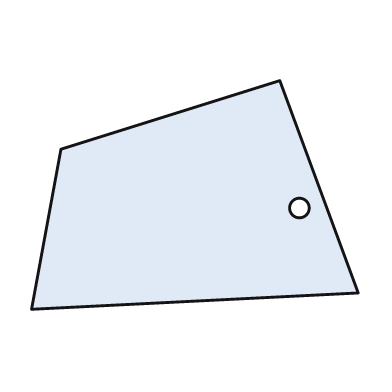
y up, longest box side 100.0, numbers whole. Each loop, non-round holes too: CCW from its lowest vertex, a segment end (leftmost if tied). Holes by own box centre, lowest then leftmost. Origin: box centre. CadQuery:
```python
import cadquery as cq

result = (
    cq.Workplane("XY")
    .moveTo(-50.0, -35.0)
    .lineTo(50.0, -30.0)
    .lineTo(26.0, 35.0)
    .lineTo(-41.0, 14.0)
    .close()
    .moveTo(32.0, -4.0)
    .circle(3.0)
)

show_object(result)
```